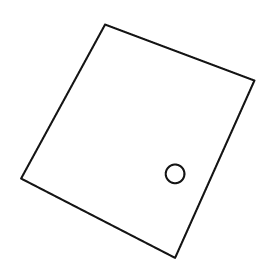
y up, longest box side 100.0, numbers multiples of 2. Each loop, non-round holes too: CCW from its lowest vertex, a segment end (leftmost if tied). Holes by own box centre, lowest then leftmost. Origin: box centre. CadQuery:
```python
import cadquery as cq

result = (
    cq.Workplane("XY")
    .moveTo(16.0, -50.0)
    .lineTo(50.0, 26.0)
    .lineTo(-14.0, 50.0)
    .lineTo(-50.0, -16.0)
    .close()
    .moveTo(16.0, -14.0)
    .circle(4.0)
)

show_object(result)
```